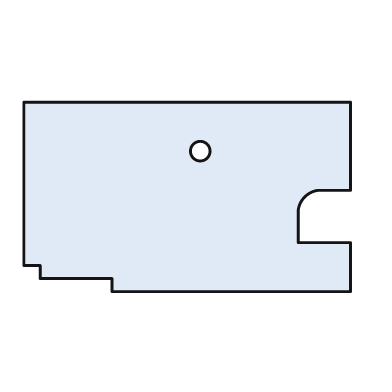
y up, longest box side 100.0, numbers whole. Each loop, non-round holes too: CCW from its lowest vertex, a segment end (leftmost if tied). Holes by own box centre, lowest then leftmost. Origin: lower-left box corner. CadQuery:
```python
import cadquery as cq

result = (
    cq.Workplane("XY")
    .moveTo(27.0, 0.0)
    .lineTo(100.0, 0.0)
    .lineTo(100.0, 15.0)
    .lineTo(84.0, 15.0)
    .lineTo(84.0, 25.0)
    .threePointArc((86.0, 29.0), (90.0, 31.0))
    .lineTo(100.0, 31.0)
    .lineTo(100.0, 58.0)
    .lineTo(0.0, 58.0)
    .lineTo(0.0, 8.0)
    .lineTo(5.0, 8.0)
    .lineTo(5.0, 4.0)
    .lineTo(27.0, 4.0)
    .close()
    .moveTo(54.0, 43.0)
    .circle(3.0)
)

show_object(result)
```